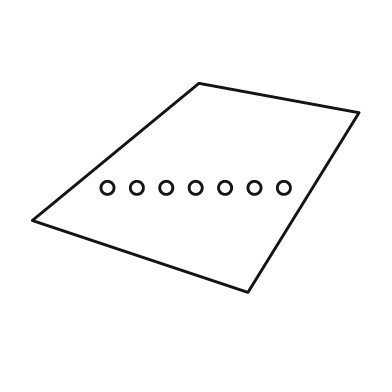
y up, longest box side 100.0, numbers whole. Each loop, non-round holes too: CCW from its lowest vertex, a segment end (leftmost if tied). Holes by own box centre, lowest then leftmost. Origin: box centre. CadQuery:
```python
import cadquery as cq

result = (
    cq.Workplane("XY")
    .moveTo(16.0, -32.0)
    .lineTo(50.0, 23.0)
    .lineTo(1.0, 32.0)
    .lineTo(-50.0, -10.0)
    .close()
    .moveTo(-27.0, 0.0)
    .circle(2.0)
    .moveTo(-18.0, 0.0)
    .circle(2.0)
    .moveTo(-9.0, 0.0)
    .circle(2.0)
    .moveTo(0.0, 0.0)
    .circle(2.0)
    .moveTo(9.0, 0.0)
    .circle(2.0)
    .moveTo(18.0, 0.0)
    .circle(2.0)
    .moveTo(27.0, 0.0)
    .circle(2.0)
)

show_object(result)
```